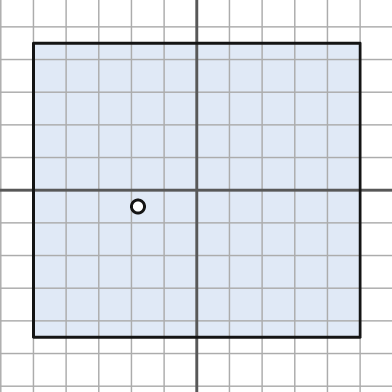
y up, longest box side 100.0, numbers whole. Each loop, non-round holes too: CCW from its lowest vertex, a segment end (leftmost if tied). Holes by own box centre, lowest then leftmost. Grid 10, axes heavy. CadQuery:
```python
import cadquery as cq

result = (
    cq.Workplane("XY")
    .moveTo(-50.0, -45.0)
    .lineTo(50.0, -45.0)
    .lineTo(50.0, 45.0)
    .lineTo(-50.0, 45.0)
    .close()
    .moveTo(-18.0, -5.0)
    .circle(2.0)
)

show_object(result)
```